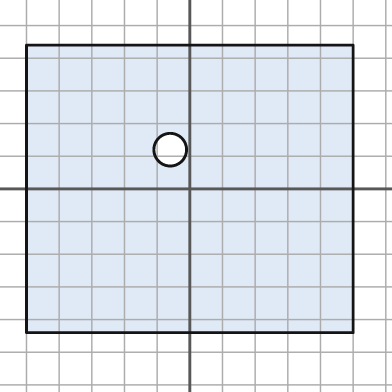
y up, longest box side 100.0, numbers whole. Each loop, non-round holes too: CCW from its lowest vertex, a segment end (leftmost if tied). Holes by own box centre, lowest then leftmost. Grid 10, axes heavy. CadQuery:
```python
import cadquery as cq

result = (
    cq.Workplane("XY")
    .moveTo(-50.0, -44.0)
    .lineTo(50.0, -44.0)
    .lineTo(50.0, 44.0)
    .lineTo(-50.0, 44.0)
    .close()
    .moveTo(-6.0, 12.0)
    .circle(5.0)
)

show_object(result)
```